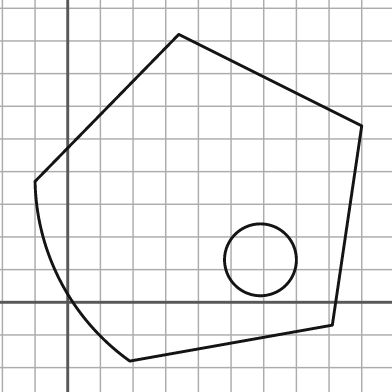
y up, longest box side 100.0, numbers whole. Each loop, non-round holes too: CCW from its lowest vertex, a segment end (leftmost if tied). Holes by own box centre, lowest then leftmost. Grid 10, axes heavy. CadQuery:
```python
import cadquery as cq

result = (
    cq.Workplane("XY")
    .moveTo(19.0, -18.0)
    .lineTo(81.0, -7.0)
    .lineTo(90.0, 54.0)
    .lineTo(34.0, 82.0)
    .lineTo(-10.0, 37.0)
    .threePointArc((-2.0, 6.0), (19.0, -18.0))
    .close()
    .moveTo(59.0, 13.0)
    .circle(11.0)
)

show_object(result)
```